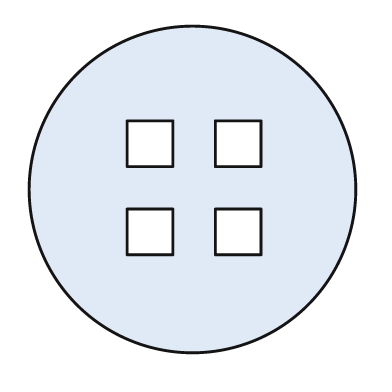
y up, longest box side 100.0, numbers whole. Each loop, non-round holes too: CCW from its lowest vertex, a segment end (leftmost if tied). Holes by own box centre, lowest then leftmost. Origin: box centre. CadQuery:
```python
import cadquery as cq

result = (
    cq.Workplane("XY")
    .moveTo(0.0, 0.0)
    .circle(50.0)
    .moveTo(-20.0, -20.0)
    .lineTo(-6.0, -20.0)
    .lineTo(-6.0, -6.0)
    .lineTo(-20.0, -6.0)
    .close()
    .moveTo(7.0, -20.0)
    .lineTo(21.0, -20.0)
    .lineTo(21.0, -6.0)
    .lineTo(7.0, -6.0)
    .close()
    .moveTo(-20.0, 7.0)
    .lineTo(-6.0, 7.0)
    .lineTo(-6.0, 21.0)
    .lineTo(-20.0, 21.0)
    .close()
    .moveTo(7.0, 7.0)
    .lineTo(21.0, 7.0)
    .lineTo(21.0, 21.0)
    .lineTo(7.0, 21.0)
    .close()
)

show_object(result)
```